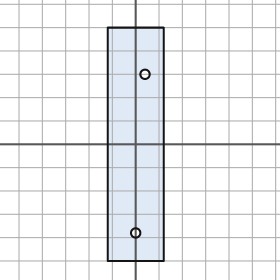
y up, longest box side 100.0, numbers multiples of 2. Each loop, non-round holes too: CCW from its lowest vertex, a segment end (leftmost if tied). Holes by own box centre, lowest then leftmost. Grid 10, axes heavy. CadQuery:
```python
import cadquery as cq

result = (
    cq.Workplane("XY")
    .moveTo(-12.0, -50.0)
    .lineTo(12.0, -50.0)
    .lineTo(12.0, 50.0)
    .lineTo(-12.0, 50.0)
    .close()
    .moveTo(0.0, -38.0)
    .circle(2.0)
    .moveTo(4.0, 30.0)
    .circle(2.0)
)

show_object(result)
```